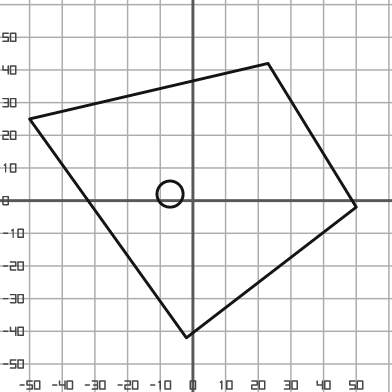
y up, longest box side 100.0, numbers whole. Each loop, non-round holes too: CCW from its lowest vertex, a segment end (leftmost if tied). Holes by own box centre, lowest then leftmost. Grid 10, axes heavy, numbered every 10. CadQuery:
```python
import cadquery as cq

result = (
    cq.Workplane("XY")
    .moveTo(-2.0, -42.0)
    .lineTo(50.0, -2.0)
    .lineTo(23.0, 42.0)
    .lineTo(-50.0, 25.0)
    .close()
    .moveTo(-7.0, 2.0)
    .circle(4.0)
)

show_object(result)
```